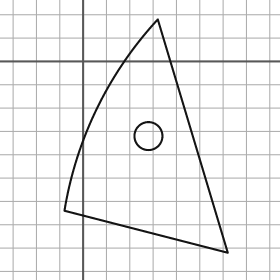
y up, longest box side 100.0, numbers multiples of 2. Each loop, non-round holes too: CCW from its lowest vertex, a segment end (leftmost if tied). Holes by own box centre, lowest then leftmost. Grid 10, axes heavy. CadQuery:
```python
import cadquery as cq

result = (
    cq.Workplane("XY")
    .moveTo(62.0, -82.0)
    .lineTo(32.0, 18.0)
    .threePointArc((6.0, -20.0), (-8.0, -64.0))
    .close()
    .moveTo(28.0, -32.0)
    .circle(6.0)
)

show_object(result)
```